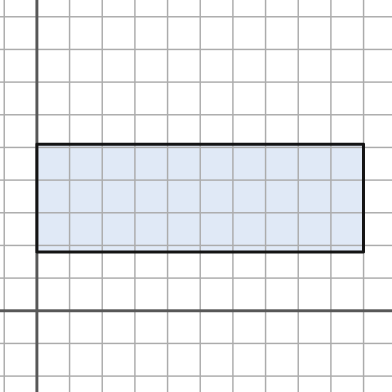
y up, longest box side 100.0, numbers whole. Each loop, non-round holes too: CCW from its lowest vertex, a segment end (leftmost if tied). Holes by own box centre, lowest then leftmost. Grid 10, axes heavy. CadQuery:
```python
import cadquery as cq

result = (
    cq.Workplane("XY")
    .moveTo(0.0, 18.0)
    .lineTo(100.0, 18.0)
    .lineTo(100.0, 51.0)
    .lineTo(0.0, 51.0)
    .close()
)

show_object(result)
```